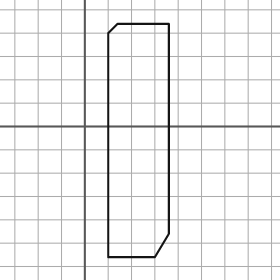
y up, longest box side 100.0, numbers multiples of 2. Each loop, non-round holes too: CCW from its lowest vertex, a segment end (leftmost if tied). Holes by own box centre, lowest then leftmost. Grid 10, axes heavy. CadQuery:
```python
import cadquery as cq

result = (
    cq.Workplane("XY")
    .moveTo(10.0, -56.0)
    .lineTo(30.0, -56.0)
    .lineTo(36.0, -46.0)
    .lineTo(36.0, 44.0)
    .lineTo(14.0, 44.0)
    .lineTo(10.0, 40.0)
    .close()
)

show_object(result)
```